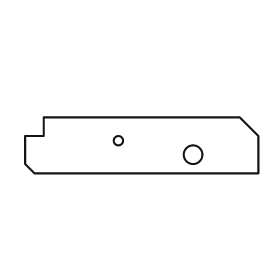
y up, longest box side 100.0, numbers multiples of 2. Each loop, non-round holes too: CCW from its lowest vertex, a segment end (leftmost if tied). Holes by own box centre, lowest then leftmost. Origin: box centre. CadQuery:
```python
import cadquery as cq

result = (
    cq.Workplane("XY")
    .moveTo(-46.0, -12.0)
    .lineTo(50.0, -12.0)
    .lineTo(50.0, 4.0)
    .lineTo(42.0, 12.0)
    .lineTo(-42.0, 12.0)
    .lineTo(-42.0, 4.0)
    .lineTo(-50.0, 4.0)
    .lineTo(-50.0, -8.0)
    .close()
    .moveTo(22.0, -4.0)
    .circle(4.0)
    .moveTo(-10.0, 2.0)
    .circle(2.0)
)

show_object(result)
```